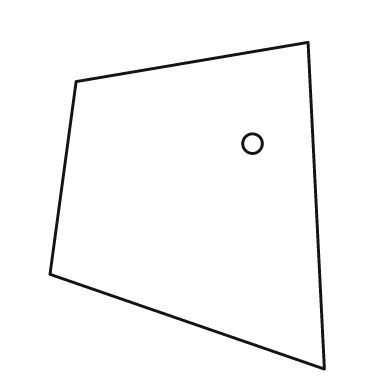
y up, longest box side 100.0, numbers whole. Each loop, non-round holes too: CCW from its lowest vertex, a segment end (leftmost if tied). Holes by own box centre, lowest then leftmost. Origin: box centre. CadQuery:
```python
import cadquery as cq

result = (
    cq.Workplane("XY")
    .moveTo(42.0, -50.0)
    .lineTo(37.0, 50.0)
    .lineTo(-34.0, 38.0)
    .lineTo(-42.0, -21.0)
    .close()
    .moveTo(20.0, 19.0)
    .circle(3.0)
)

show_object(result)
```